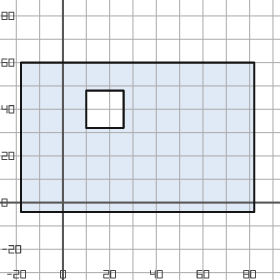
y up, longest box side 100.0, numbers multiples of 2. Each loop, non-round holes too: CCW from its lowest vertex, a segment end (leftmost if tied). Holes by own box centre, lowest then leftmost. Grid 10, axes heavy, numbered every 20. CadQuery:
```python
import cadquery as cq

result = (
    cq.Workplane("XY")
    .moveTo(-18.0, -4.0)
    .lineTo(82.0, -4.0)
    .lineTo(82.0, 60.0)
    .lineTo(-18.0, 60.0)
    .close()
    .moveTo(10.0, 32.0)
    .lineTo(26.0, 32.0)
    .lineTo(26.0, 48.0)
    .lineTo(10.0, 48.0)
    .close()
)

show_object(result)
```